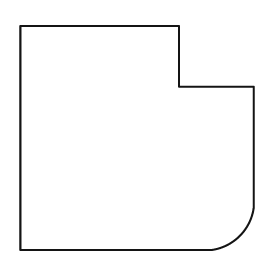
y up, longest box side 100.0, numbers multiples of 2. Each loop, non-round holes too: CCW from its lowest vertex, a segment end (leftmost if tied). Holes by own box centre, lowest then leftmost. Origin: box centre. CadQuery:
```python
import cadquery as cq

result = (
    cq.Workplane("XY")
    .moveTo(-50.0, -48.0)
    .lineTo(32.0, -48.0)
    .threePointArc((44.0, -42.0), (50.0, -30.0))
    .lineTo(50.0, 22.0)
    .lineTo(18.0, 22.0)
    .lineTo(18.0, 48.0)
    .lineTo(-50.0, 48.0)
    .close()
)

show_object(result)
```